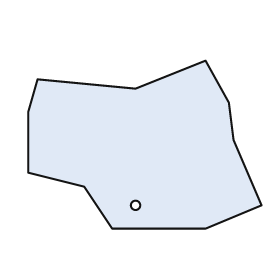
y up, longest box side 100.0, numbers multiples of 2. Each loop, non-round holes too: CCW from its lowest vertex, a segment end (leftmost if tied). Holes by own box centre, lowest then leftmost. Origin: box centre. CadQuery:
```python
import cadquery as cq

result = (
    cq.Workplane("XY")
    .moveTo(-14.0, -36.0)
    .lineTo(26.0, -36.0)
    .lineTo(50.0, -26.0)
    .lineTo(38.0, 2.0)
    .lineTo(36.0, 18.0)
    .lineTo(26.0, 36.0)
    .lineTo(-4.0, 24.0)
    .lineTo(-46.0, 28.0)
    .lineTo(-50.0, 14.0)
    .lineTo(-50.0, -12.0)
    .lineTo(-26.0, -18.0)
    .close()
    .moveTo(-4.0, -26.0)
    .circle(2.0)
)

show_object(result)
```